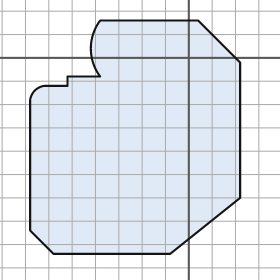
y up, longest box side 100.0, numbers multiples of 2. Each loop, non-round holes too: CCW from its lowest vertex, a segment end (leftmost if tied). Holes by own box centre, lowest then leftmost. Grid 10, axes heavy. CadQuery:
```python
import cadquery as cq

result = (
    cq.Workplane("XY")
    .moveTo(-58.0, -84.0)
    .lineTo(-8.0, -84.0)
    .lineTo(22.0, -60.0)
    .lineTo(22.0, -2.0)
    .lineTo(4.0, 16.0)
    .lineTo(-38.0, 16.0)
    .threePointArc((-42.0, 4.0), (-38.0, -8.0))
    .lineTo(-52.0, -8.0)
    .lineTo(-52.0, -12.0)
    .lineTo(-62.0, -12.0)
    .threePointArc((-66.0, -14.0), (-68.0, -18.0))
    .lineTo(-68.0, -74.0)
    .close()
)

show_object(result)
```